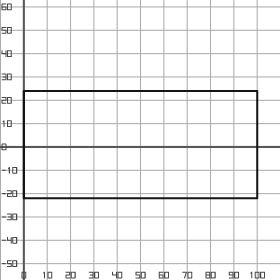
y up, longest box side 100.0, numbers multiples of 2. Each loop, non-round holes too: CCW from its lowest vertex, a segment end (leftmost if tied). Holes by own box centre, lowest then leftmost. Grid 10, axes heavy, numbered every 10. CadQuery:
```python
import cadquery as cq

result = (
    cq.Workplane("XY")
    .moveTo(0.0, -22.0)
    .lineTo(100.0, -22.0)
    .lineTo(100.0, 24.0)
    .lineTo(0.0, 24.0)
    .close()
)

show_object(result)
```